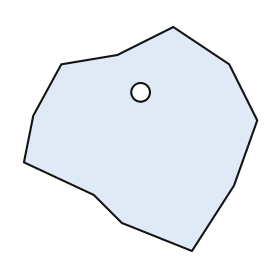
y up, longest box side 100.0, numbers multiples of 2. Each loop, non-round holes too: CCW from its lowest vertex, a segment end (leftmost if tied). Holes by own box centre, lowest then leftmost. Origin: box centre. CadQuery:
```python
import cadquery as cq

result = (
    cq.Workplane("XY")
    .moveTo(22.0, -48.0)
    .lineTo(40.0, -20.0)
    .lineTo(50.0, 8.0)
    .lineTo(38.0, 32.0)
    .lineTo(14.0, 48.0)
    .lineTo(-10.0, 36.0)
    .lineTo(-34.0, 32.0)
    .lineTo(-46.0, 10.0)
    .lineTo(-50.0, -10.0)
    .lineTo(-20.0, -24.0)
    .lineTo(-8.0, -36.0)
    .close()
    .moveTo(0.0, 20.0)
    .circle(4.0)
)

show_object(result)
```